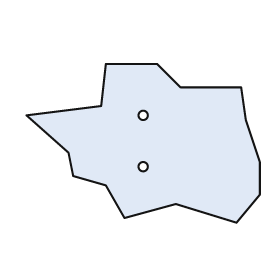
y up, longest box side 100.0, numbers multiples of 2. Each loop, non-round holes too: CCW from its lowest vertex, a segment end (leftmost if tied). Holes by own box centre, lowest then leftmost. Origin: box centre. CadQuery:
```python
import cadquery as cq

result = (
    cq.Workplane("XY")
    .moveTo(40.0, -34.0)
    .lineTo(50.0, -22.0)
    .lineTo(50.0, -8.0)
    .lineTo(44.0, 10.0)
    .lineTo(42.0, 24.0)
    .lineTo(16.0, 24.0)
    .lineTo(6.0, 34.0)
    .lineTo(-16.0, 34.0)
    .lineTo(-18.0, 16.0)
    .lineTo(-50.0, 12.0)
    .lineTo(-32.0, -4.0)
    .lineTo(-30.0, -14.0)
    .lineTo(-16.0, -18.0)
    .lineTo(-8.0, -32.0)
    .lineTo(14.0, -26.0)
    .close()
    .moveTo(0.0, -10.0)
    .circle(2.0)
    .moveTo(0.0, 12.0)
    .circle(2.0)
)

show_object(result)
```